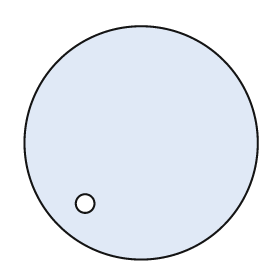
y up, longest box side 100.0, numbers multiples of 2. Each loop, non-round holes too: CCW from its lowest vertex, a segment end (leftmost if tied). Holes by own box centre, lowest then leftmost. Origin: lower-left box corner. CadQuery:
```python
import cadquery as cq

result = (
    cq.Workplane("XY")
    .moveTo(50.0, 50.0)
    .circle(50.0)
    .moveTo(26.0, 24.0)
    .circle(4.0)
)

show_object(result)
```